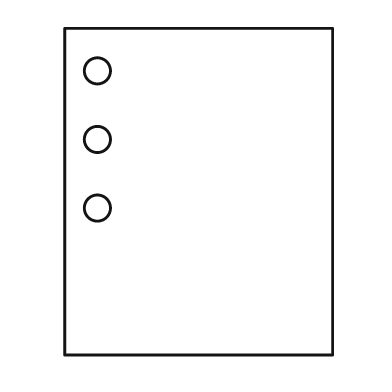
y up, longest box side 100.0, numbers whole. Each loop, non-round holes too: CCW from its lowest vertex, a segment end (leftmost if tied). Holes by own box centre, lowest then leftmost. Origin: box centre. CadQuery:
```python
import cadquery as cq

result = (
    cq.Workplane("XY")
    .moveTo(-41.0, -50.0)
    .lineTo(41.0, -50.0)
    .lineTo(41.0, 50.0)
    .lineTo(-41.0, 50.0)
    .close()
    .moveTo(-31.0, -5.0)
    .circle(4.0)
    .moveTo(-31.0, 16.0)
    .circle(4.0)
    .moveTo(-31.0, 37.0)
    .circle(4.0)
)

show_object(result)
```